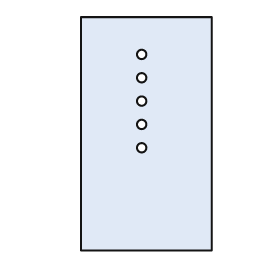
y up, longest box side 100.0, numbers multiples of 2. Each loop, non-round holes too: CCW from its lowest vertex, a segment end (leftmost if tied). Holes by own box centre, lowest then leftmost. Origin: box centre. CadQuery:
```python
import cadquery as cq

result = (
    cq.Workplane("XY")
    .moveTo(-28.0, -50.0)
    .lineTo(28.0, -50.0)
    .lineTo(28.0, 50.0)
    .lineTo(-28.0, 50.0)
    .close()
    .moveTo(-2.0, -6.0)
    .circle(2.0)
    .moveTo(-2.0, 4.0)
    .circle(2.0)
    .moveTo(-2.0, 14.0)
    .circle(2.0)
    .moveTo(-2.0, 24.0)
    .circle(2.0)
    .moveTo(-2.0, 34.0)
    .circle(2.0)
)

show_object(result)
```